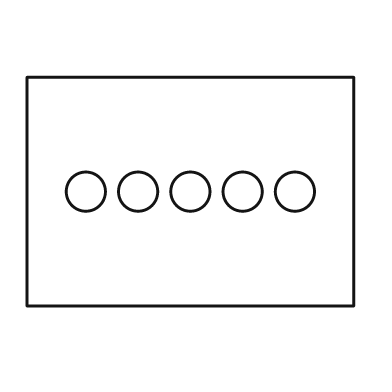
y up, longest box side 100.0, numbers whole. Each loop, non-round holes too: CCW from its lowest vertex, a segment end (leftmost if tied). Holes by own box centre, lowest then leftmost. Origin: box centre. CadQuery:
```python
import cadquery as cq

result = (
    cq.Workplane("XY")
    .moveTo(-50.0, -35.0)
    .lineTo(50.0, -35.0)
    .lineTo(50.0, 35.0)
    .lineTo(-50.0, 35.0)
    .close()
    .moveTo(-32.0, 0.0)
    .circle(6.0)
    .moveTo(-16.0, 0.0)
    .circle(6.0)
    .moveTo(0.0, 0.0)
    .circle(6.0)
    .moveTo(16.0, 0.0)
    .circle(6.0)
    .moveTo(32.0, 0.0)
    .circle(6.0)
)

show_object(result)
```